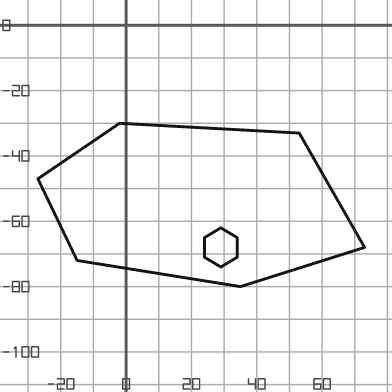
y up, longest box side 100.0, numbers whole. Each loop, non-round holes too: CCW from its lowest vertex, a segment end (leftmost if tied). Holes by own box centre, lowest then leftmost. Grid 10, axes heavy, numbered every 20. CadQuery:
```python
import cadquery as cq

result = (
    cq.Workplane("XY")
    .moveTo(35.0, -80.0)
    .lineTo(73.0, -68.0)
    .lineTo(53.0, -33.0)
    .lineTo(-2.0, -30.0)
    .lineTo(-27.0, -47.0)
    .lineTo(-15.0, -72.0)
    .close()
    .moveTo(29.0, -74.0)
    .lineTo(34.0, -71.0)
    .lineTo(34.0, -65.0)
    .lineTo(29.0, -62.0)
    .lineTo(24.0, -65.0)
    .lineTo(24.0, -71.0)
    .close()
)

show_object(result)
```